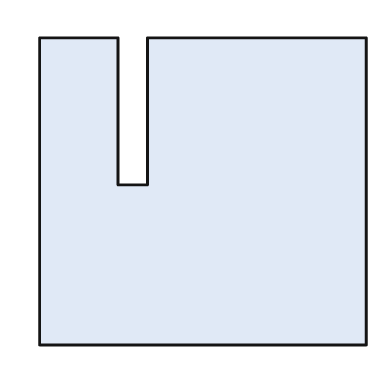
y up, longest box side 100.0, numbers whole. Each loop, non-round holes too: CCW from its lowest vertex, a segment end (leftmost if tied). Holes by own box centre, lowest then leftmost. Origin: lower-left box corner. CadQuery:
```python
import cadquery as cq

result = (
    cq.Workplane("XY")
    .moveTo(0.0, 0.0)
    .lineTo(100.0, 0.0)
    .lineTo(100.0, 94.0)
    .lineTo(33.0, 94.0)
    .lineTo(33.0, 49.0)
    .lineTo(24.0, 49.0)
    .lineTo(24.0, 94.0)
    .lineTo(0.0, 94.0)
    .close()
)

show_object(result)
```